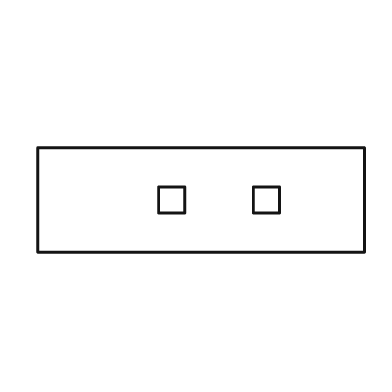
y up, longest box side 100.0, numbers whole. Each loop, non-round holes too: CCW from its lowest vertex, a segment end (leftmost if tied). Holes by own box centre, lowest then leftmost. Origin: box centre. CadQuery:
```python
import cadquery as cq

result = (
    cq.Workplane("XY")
    .moveTo(-50.0, -16.0)
    .lineTo(50.0, -16.0)
    .lineTo(50.0, 16.0)
    .lineTo(-50.0, 16.0)
    .close()
    .moveTo(-13.0, -4.0)
    .lineTo(-5.0, -4.0)
    .lineTo(-5.0, 4.0)
    .lineTo(-13.0, 4.0)
    .close()
    .moveTo(16.0, -4.0)
    .lineTo(24.0, -4.0)
    .lineTo(24.0, 4.0)
    .lineTo(16.0, 4.0)
    .close()
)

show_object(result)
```